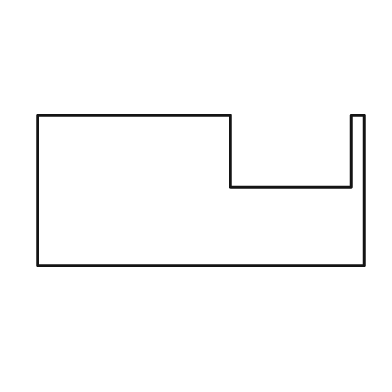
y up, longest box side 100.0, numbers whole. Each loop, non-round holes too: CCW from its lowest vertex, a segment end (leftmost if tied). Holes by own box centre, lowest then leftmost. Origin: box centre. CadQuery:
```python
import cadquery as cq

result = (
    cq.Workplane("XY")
    .moveTo(-50.0, -23.0)
    .lineTo(50.0, -23.0)
    .lineTo(50.0, 23.0)
    .lineTo(46.0, 23.0)
    .lineTo(46.0, 1.0)
    .lineTo(9.0, 1.0)
    .lineTo(9.0, 23.0)
    .lineTo(-50.0, 23.0)
    .close()
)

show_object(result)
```